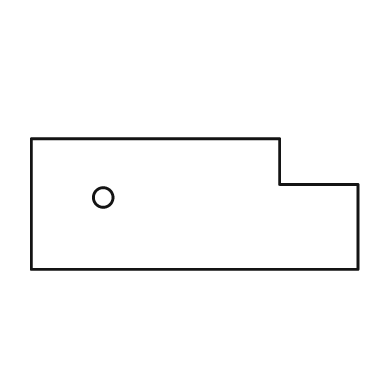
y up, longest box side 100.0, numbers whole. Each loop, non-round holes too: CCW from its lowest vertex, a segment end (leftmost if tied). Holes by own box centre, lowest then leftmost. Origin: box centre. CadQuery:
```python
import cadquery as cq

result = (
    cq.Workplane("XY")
    .moveTo(-50.0, -20.0)
    .lineTo(50.0, -20.0)
    .lineTo(50.0, 6.0)
    .lineTo(26.0, 6.0)
    .lineTo(26.0, 20.0)
    .lineTo(-50.0, 20.0)
    .close()
    .moveTo(-28.0, 2.0)
    .circle(3.0)
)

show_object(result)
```